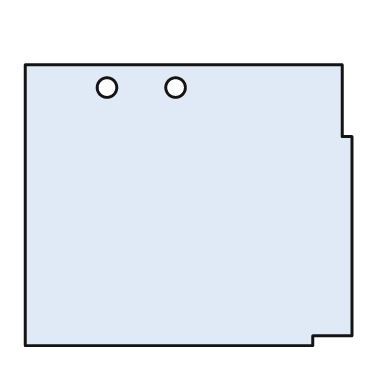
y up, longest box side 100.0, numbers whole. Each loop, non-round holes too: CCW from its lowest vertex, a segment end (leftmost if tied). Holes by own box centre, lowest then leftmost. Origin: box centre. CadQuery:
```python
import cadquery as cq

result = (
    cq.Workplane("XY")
    .moveTo(-50.0, -43.0)
    .lineTo(38.0, -43.0)
    .lineTo(38.0, -40.0)
    .lineTo(50.0, -40.0)
    .lineTo(50.0, 21.0)
    .lineTo(47.0, 21.0)
    .lineTo(47.0, 43.0)
    .lineTo(-50.0, 43.0)
    .close()
    .moveTo(-25.0, 36.0)
    .circle(3.0)
    .moveTo(-4.0, 36.0)
    .circle(3.0)
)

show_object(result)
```